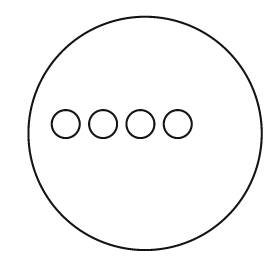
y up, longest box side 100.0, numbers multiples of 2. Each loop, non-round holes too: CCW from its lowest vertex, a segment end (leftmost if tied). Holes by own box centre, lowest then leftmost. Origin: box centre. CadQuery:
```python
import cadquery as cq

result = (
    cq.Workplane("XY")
    .moveTo(0.0, 0.0)
    .circle(50.0)
    .moveTo(-34.0, 4.0)
    .circle(6.0)
    .moveTo(-18.0, 4.0)
    .circle(6.0)
    .moveTo(-2.0, 4.0)
    .circle(6.0)
    .moveTo(14.0, 4.0)
    .circle(6.0)
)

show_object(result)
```